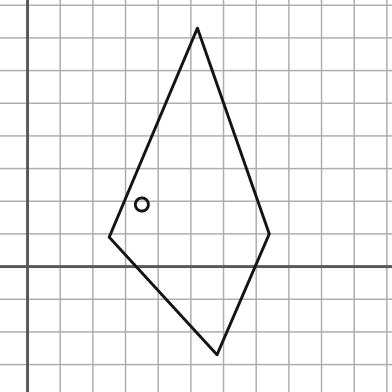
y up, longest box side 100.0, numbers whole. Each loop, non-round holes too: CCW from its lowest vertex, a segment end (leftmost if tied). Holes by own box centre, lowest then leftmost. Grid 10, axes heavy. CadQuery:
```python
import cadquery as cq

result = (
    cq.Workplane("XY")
    .moveTo(58.0, -27.0)
    .lineTo(74.0, 10.0)
    .lineTo(52.0, 73.0)
    .lineTo(25.0, 9.0)
    .close()
    .moveTo(35.0, 19.0)
    .circle(2.0)
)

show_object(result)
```